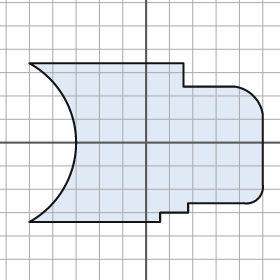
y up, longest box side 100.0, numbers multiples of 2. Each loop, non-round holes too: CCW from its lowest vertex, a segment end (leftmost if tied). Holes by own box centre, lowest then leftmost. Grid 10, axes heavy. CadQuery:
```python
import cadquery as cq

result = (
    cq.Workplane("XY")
    .moveTo(-50.0, -34.0)
    .lineTo(6.0, -34.0)
    .lineTo(6.0, -30.0)
    .lineTo(18.0, -30.0)
    .lineTo(18.0, -26.0)
    .lineTo(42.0, -26.0)
    .threePointArc((48.0, -24.0), (50.0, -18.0))
    .lineTo(50.0, 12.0)
    .threePointArc((46.0, 20.0), (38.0, 24.0))
    .lineTo(16.0, 24.0)
    .lineTo(16.0, 34.0)
    .lineTo(-50.0, 34.0)
    .threePointArc((-30.0, 0.0), (-50.0, -34.0))
    .close()
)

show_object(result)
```